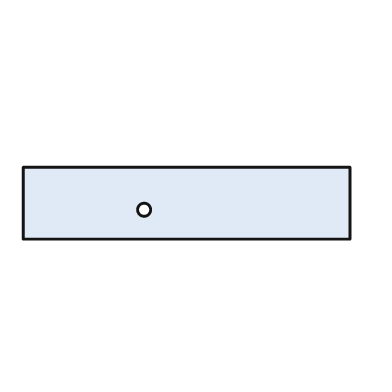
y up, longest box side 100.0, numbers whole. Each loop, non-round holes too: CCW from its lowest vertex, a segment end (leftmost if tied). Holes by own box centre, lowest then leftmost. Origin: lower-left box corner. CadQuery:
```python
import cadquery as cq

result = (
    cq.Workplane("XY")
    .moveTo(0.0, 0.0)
    .lineTo(100.0, 0.0)
    .lineTo(100.0, 22.0)
    .lineTo(0.0, 22.0)
    .close()
    .moveTo(37.0, 9.0)
    .circle(2.0)
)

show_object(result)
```